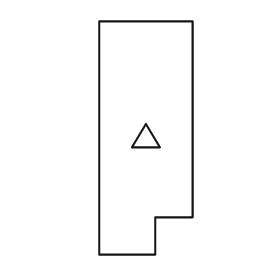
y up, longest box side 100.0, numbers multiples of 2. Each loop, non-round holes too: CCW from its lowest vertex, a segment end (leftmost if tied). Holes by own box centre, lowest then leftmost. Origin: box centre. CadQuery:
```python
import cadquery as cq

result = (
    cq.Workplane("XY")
    .moveTo(-20.0, -50.0)
    .lineTo(4.0, -50.0)
    .lineTo(4.0, -34.0)
    .lineTo(20.0, -34.0)
    .lineTo(20.0, 50.0)
    .lineTo(-20.0, 50.0)
    .close()
    .moveTo(-6.0, -4.0)
    .lineTo(6.0, -4.0)
    .lineTo(0.0, 6.0)
    .close()
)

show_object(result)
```